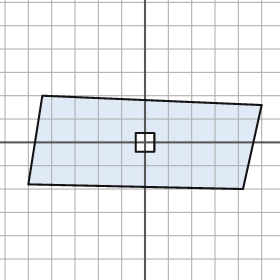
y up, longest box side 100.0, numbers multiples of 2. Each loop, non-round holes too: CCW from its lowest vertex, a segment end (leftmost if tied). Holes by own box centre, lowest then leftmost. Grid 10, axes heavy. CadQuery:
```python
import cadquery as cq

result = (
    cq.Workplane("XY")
    .moveTo(42.0, -20.0)
    .lineTo(50.0, 16.0)
    .lineTo(-44.0, 20.0)
    .lineTo(-50.0, -18.0)
    .close()
    .moveTo(-4.0, -4.0)
    .lineTo(4.0, -4.0)
    .lineTo(4.0, 4.0)
    .lineTo(-4.0, 4.0)
    .close()
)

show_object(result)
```